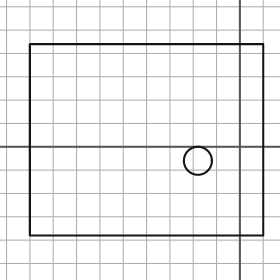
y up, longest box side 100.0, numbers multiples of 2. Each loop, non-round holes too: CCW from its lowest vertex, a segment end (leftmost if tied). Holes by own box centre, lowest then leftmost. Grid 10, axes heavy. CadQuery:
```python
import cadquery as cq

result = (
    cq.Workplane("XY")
    .moveTo(-90.0, -38.0)
    .lineTo(10.0, -38.0)
    .lineTo(10.0, 44.0)
    .lineTo(-90.0, 44.0)
    .close()
    .moveTo(-18.0, -6.0)
    .circle(6.0)
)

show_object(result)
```